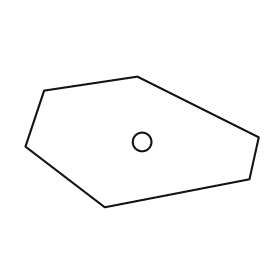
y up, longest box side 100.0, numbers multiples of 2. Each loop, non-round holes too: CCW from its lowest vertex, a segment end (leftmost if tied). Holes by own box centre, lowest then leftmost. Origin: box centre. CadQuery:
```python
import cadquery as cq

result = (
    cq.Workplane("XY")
    .moveTo(-16.0, -28.0)
    .lineTo(46.0, -16.0)
    .lineTo(50.0, 2.0)
    .lineTo(-2.0, 28.0)
    .lineTo(-42.0, 22.0)
    .lineTo(-50.0, -2.0)
    .close()
    .moveTo(0.0, 0.0)
    .circle(4.0)
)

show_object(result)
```